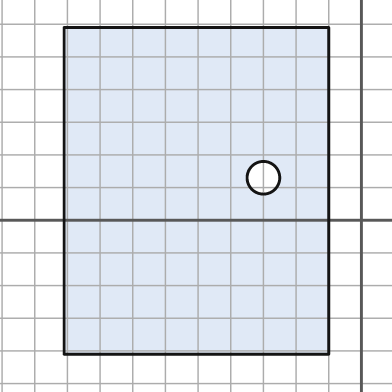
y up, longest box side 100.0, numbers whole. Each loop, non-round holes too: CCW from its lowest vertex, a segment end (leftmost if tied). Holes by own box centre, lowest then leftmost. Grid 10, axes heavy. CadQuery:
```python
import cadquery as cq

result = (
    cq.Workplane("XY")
    .moveTo(-91.0, -41.0)
    .lineTo(-10.0, -41.0)
    .lineTo(-10.0, 59.0)
    .lineTo(-91.0, 59.0)
    .close()
    .moveTo(-30.0, 13.0)
    .circle(5.0)
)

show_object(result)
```